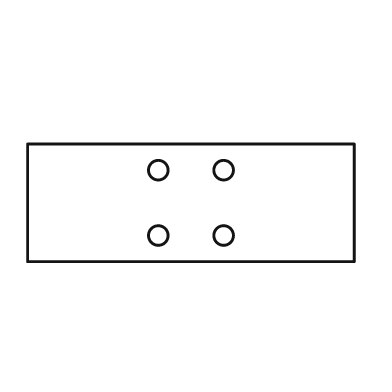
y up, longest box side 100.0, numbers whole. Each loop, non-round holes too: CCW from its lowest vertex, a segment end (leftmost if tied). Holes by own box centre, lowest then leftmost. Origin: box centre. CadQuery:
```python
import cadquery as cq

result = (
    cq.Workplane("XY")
    .moveTo(-50.0, -18.0)
    .lineTo(50.0, -18.0)
    .lineTo(50.0, 18.0)
    .lineTo(-50.0, 18.0)
    .close()
    .moveTo(-10.0, -10.0)
    .circle(3.0)
    .moveTo(10.0, -10.0)
    .circle(3.0)
    .moveTo(-10.0, 10.0)
    .circle(3.0)
    .moveTo(10.0, 10.0)
    .circle(3.0)
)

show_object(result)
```